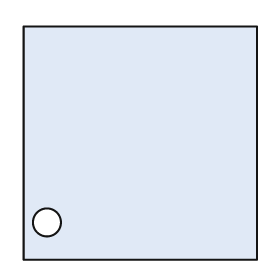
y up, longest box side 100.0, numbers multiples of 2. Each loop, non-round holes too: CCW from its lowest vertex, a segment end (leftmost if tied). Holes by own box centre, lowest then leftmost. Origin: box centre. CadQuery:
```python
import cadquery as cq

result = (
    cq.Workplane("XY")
    .moveTo(-50.0, -50.0)
    .lineTo(50.0, -50.0)
    .lineTo(50.0, 50.0)
    .lineTo(-50.0, 50.0)
    .close()
    .moveTo(-40.0, -34.0)
    .circle(6.0)
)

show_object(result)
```